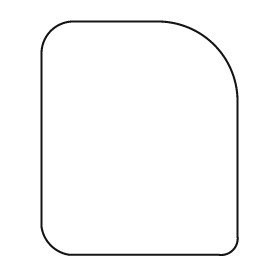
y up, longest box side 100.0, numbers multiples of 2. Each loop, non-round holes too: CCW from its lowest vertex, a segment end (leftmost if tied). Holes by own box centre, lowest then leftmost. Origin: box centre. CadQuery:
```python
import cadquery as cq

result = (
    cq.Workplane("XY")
    .moveTo(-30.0, -50.0)
    .lineTo(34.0, -50.0)
    .threePointArc((40.0, -48.0), (42.0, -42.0))
    .lineTo(42.0, 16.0)
    .threePointArc((32.0, 40.0), (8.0, 50.0))
    .lineTo(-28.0, 50.0)
    .threePointArc((-38.0, 46.0), (-42.0, 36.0))
    .lineTo(-42.0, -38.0)
    .threePointArc((-38.0, -46.0), (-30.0, -50.0))
    .close()
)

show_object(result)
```